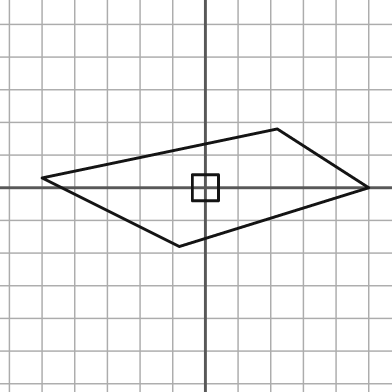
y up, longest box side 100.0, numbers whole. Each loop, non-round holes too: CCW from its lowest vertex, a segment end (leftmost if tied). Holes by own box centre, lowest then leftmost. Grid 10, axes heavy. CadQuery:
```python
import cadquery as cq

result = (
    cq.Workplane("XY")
    .moveTo(-8.0, -18.0)
    .lineTo(50.0, 0.0)
    .lineTo(22.0, 18.0)
    .lineTo(-50.0, 3.0)
    .close()
    .moveTo(-4.0, -4.0)
    .lineTo(4.0, -4.0)
    .lineTo(4.0, 4.0)
    .lineTo(-4.0, 4.0)
    .close()
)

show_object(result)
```